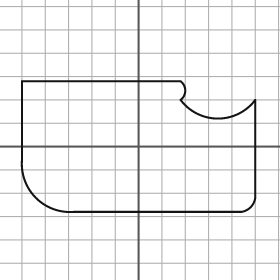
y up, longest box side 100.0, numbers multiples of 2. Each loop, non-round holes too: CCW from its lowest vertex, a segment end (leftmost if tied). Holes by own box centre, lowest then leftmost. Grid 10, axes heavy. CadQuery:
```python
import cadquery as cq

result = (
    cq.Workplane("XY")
    .moveTo(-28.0, -28.0)
    .lineTo(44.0, -28.0)
    .threePointArc((48.0, -26.0), (50.0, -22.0))
    .lineTo(50.0, 20.0)
    .threePointArc((34.0, 12.0), (18.0, 20.0))
    .threePointArc((20.0, 24.0), (18.0, 28.0))
    .lineTo(-50.0, 28.0)
    .lineTo(-50.0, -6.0)
    .threePointArc((-44.0, -22.0), (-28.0, -28.0))
    .close()
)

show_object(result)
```